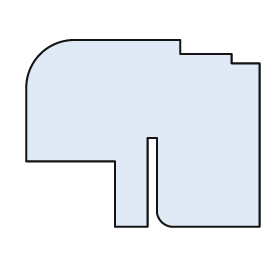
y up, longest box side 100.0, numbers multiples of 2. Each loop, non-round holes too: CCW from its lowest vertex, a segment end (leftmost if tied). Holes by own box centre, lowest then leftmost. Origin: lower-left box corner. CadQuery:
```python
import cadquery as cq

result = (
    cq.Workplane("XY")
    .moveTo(38.0, 0.0)
    .lineTo(52.0, 0.0)
    .lineTo(52.0, 38.0)
    .lineTo(56.0, 38.0)
    .lineTo(56.0, 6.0)
    .threePointArc((58.0, 2.0), (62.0, 0.0))
    .lineTo(100.0, 0.0)
    .lineTo(100.0, 70.0)
    .lineTo(88.0, 70.0)
    .lineTo(88.0, 74.0)
    .lineTo(66.0, 74.0)
    .lineTo(66.0, 80.0)
    .lineTo(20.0, 80.0)
    .threePointArc((6.0, 74.0), (0.0, 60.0))
    .lineTo(0.0, 28.0)
    .lineTo(38.0, 28.0)
    .close()
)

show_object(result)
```